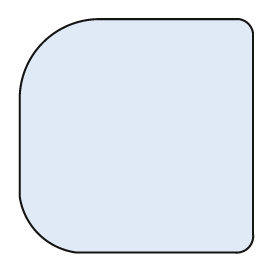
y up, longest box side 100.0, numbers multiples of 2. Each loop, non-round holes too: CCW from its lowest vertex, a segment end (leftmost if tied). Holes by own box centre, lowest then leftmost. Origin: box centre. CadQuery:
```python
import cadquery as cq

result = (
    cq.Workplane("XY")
    .moveTo(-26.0, -50.0)
    .lineTo(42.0, -50.0)
    .threePointArc((48.0, -48.0), (50.0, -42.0))
    .lineTo(50.0, 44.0)
    .threePointArc((48.0, 48.0), (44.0, 50.0))
    .lineTo(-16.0, 50.0)
    .threePointArc((-40.0, 40.0), (-50.0, 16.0))
    .lineTo(-50.0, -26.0)
    .threePointArc((-42.0, -42.0), (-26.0, -50.0))
    .close()
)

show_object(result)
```